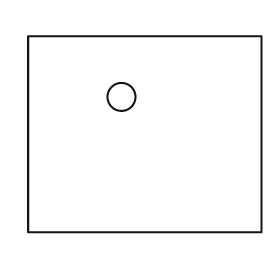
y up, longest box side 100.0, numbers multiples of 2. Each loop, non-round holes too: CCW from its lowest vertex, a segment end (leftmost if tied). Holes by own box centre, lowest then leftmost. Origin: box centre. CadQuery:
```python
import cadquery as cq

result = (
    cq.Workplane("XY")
    .moveTo(-50.0, -42.0)
    .lineTo(50.0, -42.0)
    .lineTo(50.0, 42.0)
    .lineTo(-50.0, 42.0)
    .close()
    .moveTo(-10.0, 16.0)
    .circle(6.0)
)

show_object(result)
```